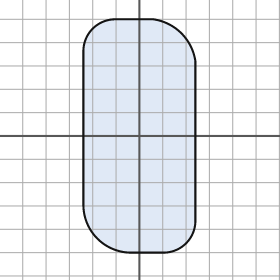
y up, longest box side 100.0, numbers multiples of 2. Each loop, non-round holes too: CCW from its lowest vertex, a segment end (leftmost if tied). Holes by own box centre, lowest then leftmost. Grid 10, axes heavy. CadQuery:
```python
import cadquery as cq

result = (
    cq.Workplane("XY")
    .moveTo(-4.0, -50.0)
    .lineTo(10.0, -50.0)
    .threePointArc((20.0, -46.0), (24.0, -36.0))
    .lineTo(24.0, 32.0)
    .threePointArc((18.0, 44.0), (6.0, 50.0))
    .lineTo(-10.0, 50.0)
    .threePointArc((-20.0, 46.0), (-24.0, 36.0))
    .lineTo(-24.0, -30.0)
    .threePointArc((-18.0, -44.0), (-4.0, -50.0))
    .close()
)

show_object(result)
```